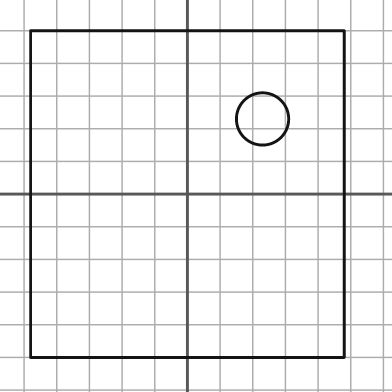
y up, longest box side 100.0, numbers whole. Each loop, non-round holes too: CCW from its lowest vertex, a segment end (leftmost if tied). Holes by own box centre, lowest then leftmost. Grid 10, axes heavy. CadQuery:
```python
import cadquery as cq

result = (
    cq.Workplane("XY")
    .moveTo(-48.0, -50.0)
    .lineTo(48.0, -50.0)
    .lineTo(48.0, 50.0)
    .lineTo(-48.0, 50.0)
    .close()
    .moveTo(23.0, 23.0)
    .circle(8.0)
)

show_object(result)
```